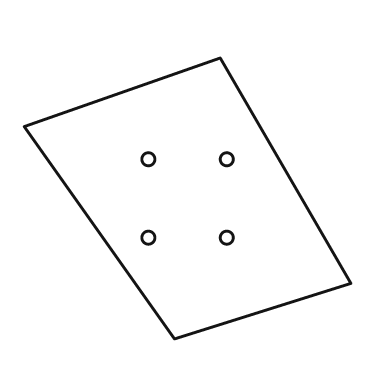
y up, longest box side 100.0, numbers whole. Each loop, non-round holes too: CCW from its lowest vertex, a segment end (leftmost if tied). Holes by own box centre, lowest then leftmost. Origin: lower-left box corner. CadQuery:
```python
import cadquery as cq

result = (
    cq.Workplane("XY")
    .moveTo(46.0, 0.0)
    .lineTo(100.0, 17.0)
    .lineTo(60.0, 86.0)
    .lineTo(0.0, 65.0)
    .close()
    .moveTo(38.0, 31.0)
    .circle(2.0)
    .moveTo(62.0, 31.0)
    .circle(2.0)
    .moveTo(38.0, 55.0)
    .circle(2.0)
    .moveTo(62.0, 55.0)
    .circle(2.0)
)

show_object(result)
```